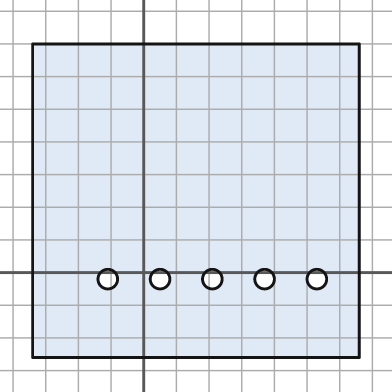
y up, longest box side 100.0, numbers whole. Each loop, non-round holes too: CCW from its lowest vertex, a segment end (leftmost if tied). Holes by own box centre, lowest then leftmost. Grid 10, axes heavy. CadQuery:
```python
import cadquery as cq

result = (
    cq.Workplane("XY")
    .moveTo(-34.0, -26.0)
    .lineTo(66.0, -26.0)
    .lineTo(66.0, 70.0)
    .lineTo(-34.0, 70.0)
    .close()
    .moveTo(-11.0, -2.0)
    .circle(3.0)
    .moveTo(5.0, -2.0)
    .circle(3.0)
    .moveTo(21.0, -2.0)
    .circle(3.0)
    .moveTo(37.0, -2.0)
    .circle(3.0)
    .moveTo(53.0, -2.0)
    .circle(3.0)
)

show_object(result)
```